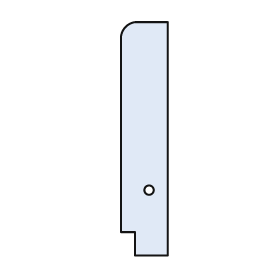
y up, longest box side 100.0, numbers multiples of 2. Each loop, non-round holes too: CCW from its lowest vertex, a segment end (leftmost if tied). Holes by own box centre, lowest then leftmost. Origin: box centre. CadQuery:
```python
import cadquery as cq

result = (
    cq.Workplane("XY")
    .moveTo(-4.0, -50.0)
    .lineTo(10.0, -50.0)
    .lineTo(10.0, 50.0)
    .lineTo(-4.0, 50.0)
    .threePointArc((-8.0, 48.0), (-10.0, 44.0))
    .lineTo(-10.0, -40.0)
    .lineTo(-4.0, -40.0)
    .close()
    .moveTo(2.0, -22.0)
    .circle(2.0)
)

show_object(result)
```